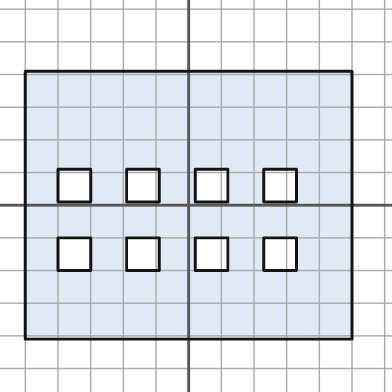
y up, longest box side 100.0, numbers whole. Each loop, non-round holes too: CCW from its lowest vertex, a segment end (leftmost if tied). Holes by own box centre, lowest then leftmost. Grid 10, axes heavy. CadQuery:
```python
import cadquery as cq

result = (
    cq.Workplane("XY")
    .moveTo(-50.0, -41.0)
    .lineTo(50.0, -41.0)
    .lineTo(50.0, 41.0)
    .lineTo(-50.0, 41.0)
    .close()
    .moveTo(-40.0, -20.0)
    .lineTo(-30.0, -20.0)
    .lineTo(-30.0, -10.0)
    .lineTo(-40.0, -10.0)
    .close()
    .moveTo(-19.0, -20.0)
    .lineTo(-9.0, -20.0)
    .lineTo(-9.0, -10.0)
    .lineTo(-19.0, -10.0)
    .close()
    .moveTo(2.0, -20.0)
    .lineTo(12.0, -20.0)
    .lineTo(12.0, -10.0)
    .lineTo(2.0, -10.0)
    .close()
    .moveTo(23.0, -20.0)
    .lineTo(33.0, -20.0)
    .lineTo(33.0, -10.0)
    .lineTo(23.0, -10.0)
    .close()
    .moveTo(-40.0, 1.0)
    .lineTo(-30.0, 1.0)
    .lineTo(-30.0, 11.0)
    .lineTo(-40.0, 11.0)
    .close()
    .moveTo(-19.0, 1.0)
    .lineTo(-9.0, 1.0)
    .lineTo(-9.0, 11.0)
    .lineTo(-19.0, 11.0)
    .close()
    .moveTo(2.0, 1.0)
    .lineTo(12.0, 1.0)
    .lineTo(12.0, 11.0)
    .lineTo(2.0, 11.0)
    .close()
    .moveTo(23.0, 1.0)
    .lineTo(33.0, 1.0)
    .lineTo(33.0, 11.0)
    .lineTo(23.0, 11.0)
    .close()
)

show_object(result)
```